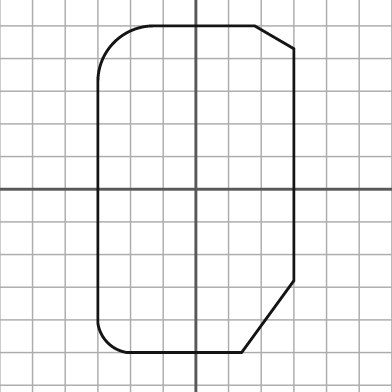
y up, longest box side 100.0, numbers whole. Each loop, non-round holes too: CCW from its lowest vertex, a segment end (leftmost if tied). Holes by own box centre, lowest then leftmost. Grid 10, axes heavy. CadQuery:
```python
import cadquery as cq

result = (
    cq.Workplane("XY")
    .moveTo(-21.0, -50.0)
    .lineTo(14.0, -50.0)
    .lineTo(30.0, -28.0)
    .lineTo(30.0, 43.0)
    .lineTo(18.0, 50.0)
    .lineTo(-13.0, 50.0)
    .threePointArc((-25.0, 45.0), (-30.0, 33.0))
    .lineTo(-30.0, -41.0)
    .threePointArc((-27.0, -47.0), (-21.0, -50.0))
    .close()
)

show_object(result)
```